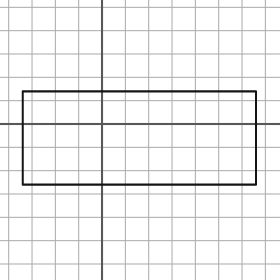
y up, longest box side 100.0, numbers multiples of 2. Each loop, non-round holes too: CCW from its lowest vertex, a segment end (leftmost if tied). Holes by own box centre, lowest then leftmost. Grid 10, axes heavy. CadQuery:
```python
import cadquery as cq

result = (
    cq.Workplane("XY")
    .moveTo(-34.0, -26.0)
    .lineTo(66.0, -26.0)
    .lineTo(66.0, 14.0)
    .lineTo(-34.0, 14.0)
    .close()
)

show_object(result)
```